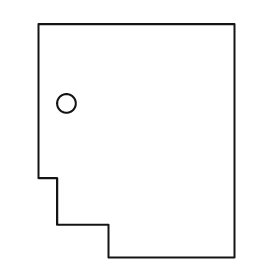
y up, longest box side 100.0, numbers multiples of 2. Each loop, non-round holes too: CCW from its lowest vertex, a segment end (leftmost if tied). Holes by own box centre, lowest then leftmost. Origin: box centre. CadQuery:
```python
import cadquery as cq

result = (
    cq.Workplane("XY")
    .moveTo(-12.0, -50.0)
    .lineTo(42.0, -50.0)
    .lineTo(42.0, 50.0)
    .lineTo(-42.0, 50.0)
    .lineTo(-42.0, -16.0)
    .lineTo(-34.0, -16.0)
    .lineTo(-34.0, -36.0)
    .lineTo(-12.0, -36.0)
    .close()
    .moveTo(-30.0, 16.0)
    .circle(4.0)
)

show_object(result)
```